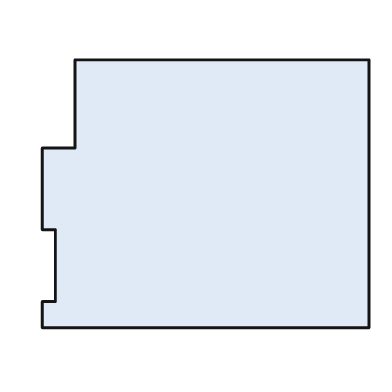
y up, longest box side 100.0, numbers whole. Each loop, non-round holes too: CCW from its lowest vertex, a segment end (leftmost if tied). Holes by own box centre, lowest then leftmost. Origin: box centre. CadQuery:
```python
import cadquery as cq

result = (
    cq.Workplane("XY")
    .moveTo(-50.0, -41.0)
    .lineTo(50.0, -41.0)
    .lineTo(50.0, 41.0)
    .lineTo(-40.0, 41.0)
    .lineTo(-40.0, 14.0)
    .lineTo(-50.0, 14.0)
    .lineTo(-50.0, -11.0)
    .lineTo(-46.0, -11.0)
    .lineTo(-46.0, -33.0)
    .lineTo(-50.0, -33.0)
    .close()
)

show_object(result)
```